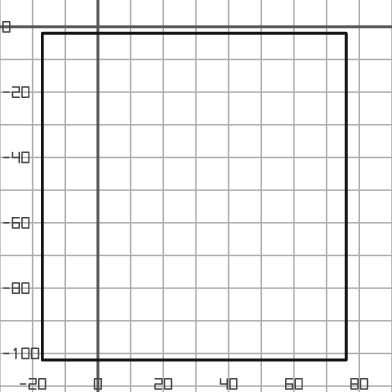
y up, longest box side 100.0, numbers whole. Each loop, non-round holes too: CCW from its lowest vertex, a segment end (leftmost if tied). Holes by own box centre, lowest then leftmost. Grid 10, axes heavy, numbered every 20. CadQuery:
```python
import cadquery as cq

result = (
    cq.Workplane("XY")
    .moveTo(-17.0, -102.0)
    .lineTo(76.0, -102.0)
    .lineTo(76.0, -2.0)
    .lineTo(-17.0, -2.0)
    .close()
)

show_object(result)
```